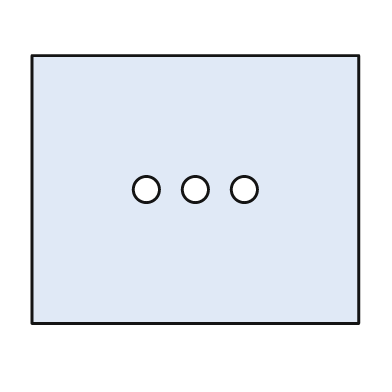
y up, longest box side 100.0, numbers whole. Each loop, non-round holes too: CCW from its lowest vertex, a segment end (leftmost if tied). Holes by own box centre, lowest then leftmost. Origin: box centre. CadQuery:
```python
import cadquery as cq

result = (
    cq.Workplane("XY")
    .moveTo(-50.0, -41.0)
    .lineTo(50.0, -41.0)
    .lineTo(50.0, 41.0)
    .lineTo(-50.0, 41.0)
    .close()
    .moveTo(-15.0, 0.0)
    .circle(4.0)
    .moveTo(0.0, 0.0)
    .circle(4.0)
    .moveTo(15.0, 0.0)
    .circle(4.0)
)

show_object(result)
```